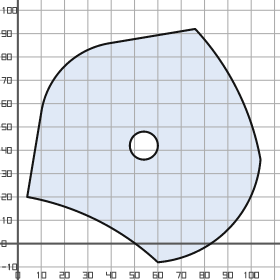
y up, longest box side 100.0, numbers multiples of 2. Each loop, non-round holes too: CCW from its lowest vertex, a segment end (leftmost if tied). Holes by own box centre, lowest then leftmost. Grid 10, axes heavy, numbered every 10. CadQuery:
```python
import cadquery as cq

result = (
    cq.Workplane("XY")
    .moveTo(60.0, -8.0)
    .threePointArc((90.0, 6.0), (104.0, 36.0))
    .threePointArc((94.0, 66.0), (76.0, 92.0))
    .lineTo(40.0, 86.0)
    .threePointArc((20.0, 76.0), (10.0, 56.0))
    .lineTo(4.0, 20.0)
    .threePointArc((34.0, 10.0), (60.0, -8.0))
    .close()
    .moveTo(54.0, 42.0)
    .circle(6.0)
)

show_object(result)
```